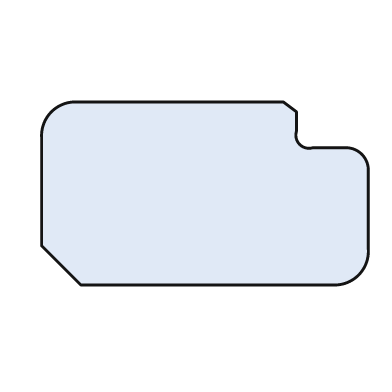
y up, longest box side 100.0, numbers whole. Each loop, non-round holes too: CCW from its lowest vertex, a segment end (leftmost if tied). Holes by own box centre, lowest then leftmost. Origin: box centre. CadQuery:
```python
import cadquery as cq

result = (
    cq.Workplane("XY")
    .moveTo(-38.0, -28.0)
    .lineTo(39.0, -28.0)
    .threePointArc((47.0, -25.0), (50.0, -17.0))
    .lineTo(50.0, 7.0)
    .threePointArc((48.0, 12.0), (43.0, 14.0))
    .lineTo(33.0, 14.0)
    .threePointArc((29.0, 15.0), (28.0, 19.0))
    .lineTo(28.0, 25.0)
    .lineTo(24.0, 28.0)
    .lineTo(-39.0, 28.0)
    .threePointArc((-47.0, 25.0), (-50.0, 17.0))
    .lineTo(-50.0, -16.0)
    .close()
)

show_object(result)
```